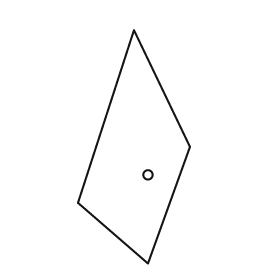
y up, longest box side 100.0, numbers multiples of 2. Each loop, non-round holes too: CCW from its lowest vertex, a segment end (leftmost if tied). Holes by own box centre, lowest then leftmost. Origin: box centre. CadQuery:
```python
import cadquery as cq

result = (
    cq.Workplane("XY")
    .moveTo(6.0, -50.0)
    .lineTo(24.0, 0.0)
    .lineTo(0.0, 50.0)
    .lineTo(-24.0, -24.0)
    .close()
    .moveTo(6.0, -12.0)
    .circle(2.0)
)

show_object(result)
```